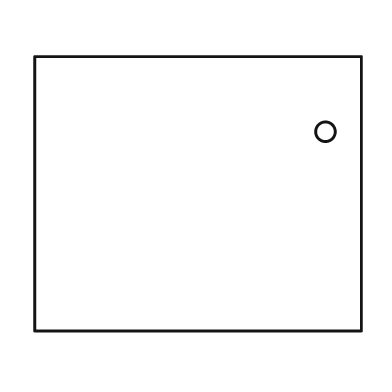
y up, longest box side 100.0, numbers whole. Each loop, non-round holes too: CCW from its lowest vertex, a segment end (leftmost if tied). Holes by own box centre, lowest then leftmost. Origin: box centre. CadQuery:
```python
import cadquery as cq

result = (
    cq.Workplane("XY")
    .moveTo(-50.0, -42.0)
    .lineTo(50.0, -42.0)
    .lineTo(50.0, 42.0)
    .lineTo(-50.0, 42.0)
    .close()
    .moveTo(39.0, 19.0)
    .circle(3.0)
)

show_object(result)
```